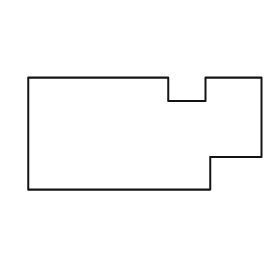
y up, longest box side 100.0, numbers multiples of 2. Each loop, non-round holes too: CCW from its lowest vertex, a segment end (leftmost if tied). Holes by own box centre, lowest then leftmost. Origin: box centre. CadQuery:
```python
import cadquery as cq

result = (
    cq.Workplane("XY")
    .moveTo(-50.0, -24.0)
    .lineTo(28.0, -24.0)
    .lineTo(28.0, -10.0)
    .lineTo(50.0, -10.0)
    .lineTo(50.0, 24.0)
    .lineTo(26.0, 24.0)
    .lineTo(26.0, 14.0)
    .lineTo(10.0, 14.0)
    .lineTo(10.0, 24.0)
    .lineTo(-50.0, 24.0)
    .close()
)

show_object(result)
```